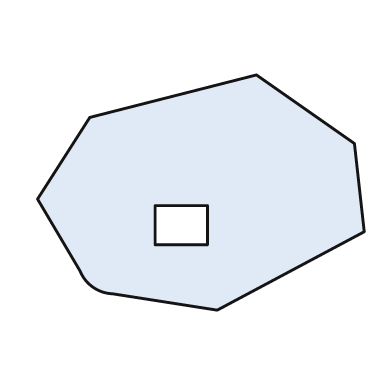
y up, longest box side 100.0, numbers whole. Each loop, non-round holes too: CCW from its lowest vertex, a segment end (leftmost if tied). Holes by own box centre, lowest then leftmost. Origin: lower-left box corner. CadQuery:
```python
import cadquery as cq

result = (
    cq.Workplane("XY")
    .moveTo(55.0, 0.0)
    .lineTo(100.0, 24.0)
    .lineTo(97.0, 51.0)
    .lineTo(67.0, 72.0)
    .lineTo(16.0, 59.0)
    .lineTo(0.0, 34.0)
    .lineTo(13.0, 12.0)
    .threePointArc((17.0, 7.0), (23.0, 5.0))
    .close()
    .moveTo(36.0, 20.0)
    .lineTo(52.0, 20.0)
    .lineTo(52.0, 32.0)
    .lineTo(36.0, 32.0)
    .close()
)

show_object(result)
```